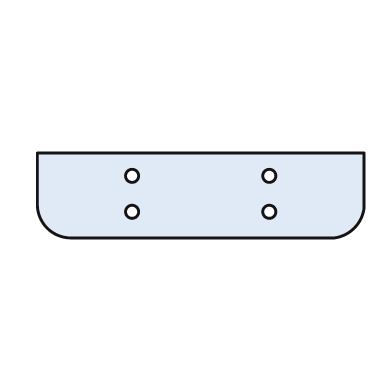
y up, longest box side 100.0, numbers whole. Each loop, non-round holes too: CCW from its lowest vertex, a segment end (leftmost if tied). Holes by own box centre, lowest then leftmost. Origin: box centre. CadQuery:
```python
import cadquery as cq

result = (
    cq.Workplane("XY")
    .moveTo(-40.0, -13.0)
    .lineTo(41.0, -13.0)
    .threePointArc((47.0, -10.0), (50.0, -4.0))
    .lineTo(50.0, 13.0)
    .lineTo(-50.0, 13.0)
    .lineTo(-50.0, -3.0)
    .threePointArc((-47.0, -10.0), (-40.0, -13.0))
    .close()
    .moveTo(-21.0, -5.0)
    .circle(2.0)
    .moveTo(21.0, -5.0)
    .circle(2.0)
    .moveTo(-21.0, 6.0)
    .circle(2.0)
    .moveTo(21.0, 6.0)
    .circle(2.0)
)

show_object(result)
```